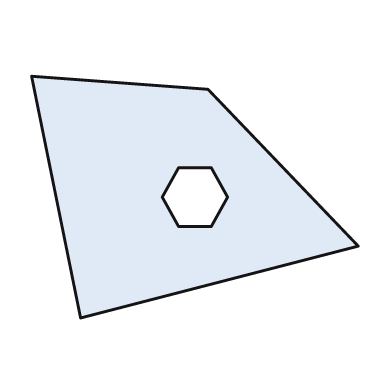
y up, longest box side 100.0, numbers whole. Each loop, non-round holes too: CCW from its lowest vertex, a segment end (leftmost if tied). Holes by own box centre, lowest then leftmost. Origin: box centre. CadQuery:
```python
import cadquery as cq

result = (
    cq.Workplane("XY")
    .moveTo(-35.0, -37.0)
    .lineTo(50.0, -15.0)
    .lineTo(4.0, 33.0)
    .lineTo(-50.0, 37.0)
    .close()
    .moveTo(-5.0, -9.0)
    .lineTo(5.0, -9.0)
    .lineTo(10.0, 0.0)
    .lineTo(5.0, 9.0)
    .lineTo(-5.0, 9.0)
    .lineTo(-10.0, 0.0)
    .close()
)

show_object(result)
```